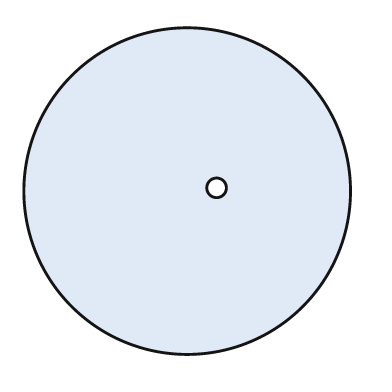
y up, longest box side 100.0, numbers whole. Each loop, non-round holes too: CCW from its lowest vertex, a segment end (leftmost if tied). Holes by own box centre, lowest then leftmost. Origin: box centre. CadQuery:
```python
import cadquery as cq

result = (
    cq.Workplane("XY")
    .moveTo(0.0, 0.0)
    .circle(50.0)
    .moveTo(9.0, 1.0)
    .circle(3.0)
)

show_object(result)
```